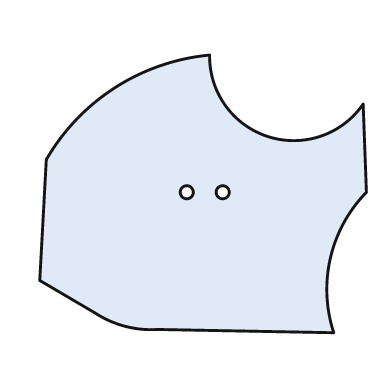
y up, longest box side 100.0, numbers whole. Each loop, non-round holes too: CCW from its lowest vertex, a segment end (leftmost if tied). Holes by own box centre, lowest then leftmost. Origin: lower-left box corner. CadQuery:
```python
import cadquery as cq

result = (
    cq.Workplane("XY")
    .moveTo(90.0, 0.0)
    .threePointArc((89.0, 23.0), (100.0, 43.0))
    .lineTo(99.0, 70.0)
    .threePointArc((70.0, 60.0), (52.0, 85.0))
    .threePointArc((23.0, 75.0), (2.0, 53.0))
    .lineTo(0.0, 16.0)
    .lineTo(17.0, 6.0)
    .threePointArc((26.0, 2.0), (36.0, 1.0))
    .close()
    .moveTo(45.0, 43.0)
    .circle(2.0)
    .moveTo(56.0, 43.0)
    .circle(2.0)
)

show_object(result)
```